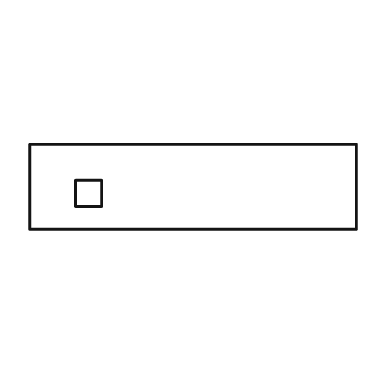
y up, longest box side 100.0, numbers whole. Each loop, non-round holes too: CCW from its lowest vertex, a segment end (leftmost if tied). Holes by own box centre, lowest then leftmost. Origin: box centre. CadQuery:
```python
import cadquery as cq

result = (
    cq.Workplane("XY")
    .moveTo(-50.0, -13.0)
    .lineTo(50.0, -13.0)
    .lineTo(50.0, 13.0)
    .lineTo(-50.0, 13.0)
    .close()
    .moveTo(-36.0, -6.0)
    .lineTo(-28.0, -6.0)
    .lineTo(-28.0, 2.0)
    .lineTo(-36.0, 2.0)
    .close()
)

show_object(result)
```